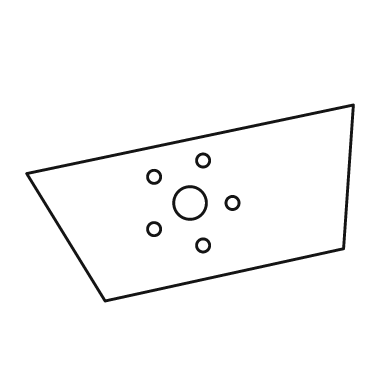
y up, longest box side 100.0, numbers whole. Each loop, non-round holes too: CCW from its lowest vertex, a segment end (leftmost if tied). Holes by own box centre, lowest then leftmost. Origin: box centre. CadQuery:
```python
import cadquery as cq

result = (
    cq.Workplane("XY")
    .moveTo(-26.0, -30.0)
    .lineTo(47.0, -14.0)
    .lineTo(50.0, 30.0)
    .lineTo(-50.0, 9.0)
    .close()
    .moveTo(4.0, -13.0)
    .circle(2.0)
    .moveTo(-11.0, -8.0)
    .circle(2.0)
    .moveTo(0.0, 0.0)
    .circle(5.0)
    .moveTo(13.0, 0.0)
    .circle(2.0)
    .moveTo(-11.0, 8.0)
    .circle(2.0)
    .moveTo(4.0, 13.0)
    .circle(2.0)
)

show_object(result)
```